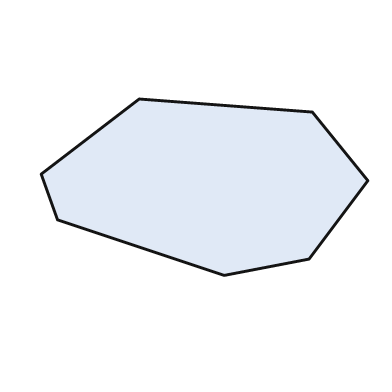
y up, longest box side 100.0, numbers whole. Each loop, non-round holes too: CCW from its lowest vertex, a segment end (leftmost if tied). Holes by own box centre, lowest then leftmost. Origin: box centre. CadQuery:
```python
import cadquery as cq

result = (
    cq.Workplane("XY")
    .moveTo(6.0, -27.0)
    .lineTo(32.0, -22.0)
    .lineTo(50.0, 2.0)
    .lineTo(33.0, 23.0)
    .lineTo(-20.0, 27.0)
    .lineTo(-50.0, 4.0)
    .lineTo(-45.0, -10.0)
    .close()
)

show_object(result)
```